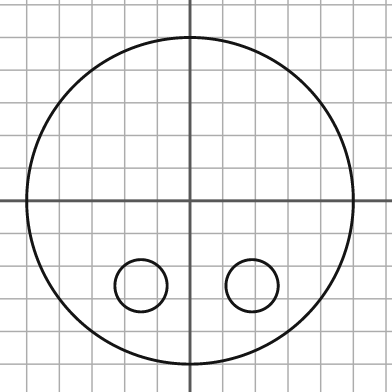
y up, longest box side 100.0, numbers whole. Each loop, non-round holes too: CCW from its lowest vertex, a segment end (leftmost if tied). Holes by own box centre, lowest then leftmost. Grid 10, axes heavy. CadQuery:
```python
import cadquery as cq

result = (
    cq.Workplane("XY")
    .moveTo(0.0, 0.0)
    .circle(50.0)
    .moveTo(-15.0, -26.0)
    .circle(8.0)
    .moveTo(19.0, -26.0)
    .circle(8.0)
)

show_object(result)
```